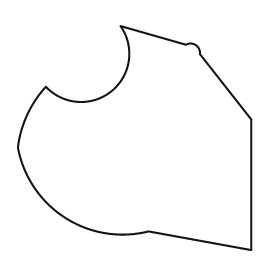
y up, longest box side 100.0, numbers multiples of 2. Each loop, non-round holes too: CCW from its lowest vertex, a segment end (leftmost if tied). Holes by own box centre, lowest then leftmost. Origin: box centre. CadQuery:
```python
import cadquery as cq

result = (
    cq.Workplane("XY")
    .moveTo(50.0, -48.0)
    .lineTo(50.0, 8.0)
    .lineTo(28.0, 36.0)
    .threePointArc((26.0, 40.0), (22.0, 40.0))
    .lineTo(-6.0, 48.0)
    .threePointArc((-10.0, 20.0), (-38.0, 22.0))
    .threePointArc((-46.0, 10.0), (-50.0, -4.0))
    .threePointArc((-30.0, -34.0), (6.0, -40.0))
    .close()
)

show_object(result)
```